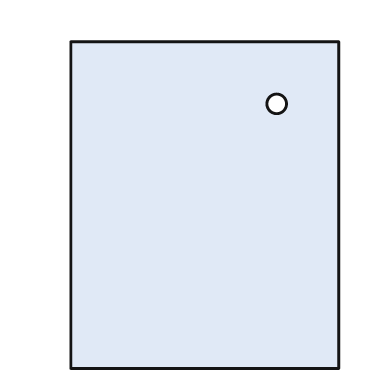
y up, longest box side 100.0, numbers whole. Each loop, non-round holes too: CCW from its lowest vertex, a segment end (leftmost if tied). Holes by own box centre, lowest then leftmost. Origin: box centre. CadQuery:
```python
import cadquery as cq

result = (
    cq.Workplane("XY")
    .moveTo(-41.0, -50.0)
    .lineTo(41.0, -50.0)
    .lineTo(41.0, 50.0)
    .lineTo(-41.0, 50.0)
    .close()
    .moveTo(22.0, 31.0)
    .circle(3.0)
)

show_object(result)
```